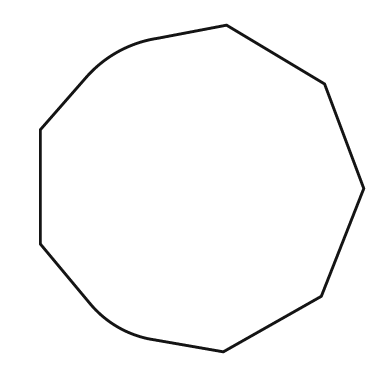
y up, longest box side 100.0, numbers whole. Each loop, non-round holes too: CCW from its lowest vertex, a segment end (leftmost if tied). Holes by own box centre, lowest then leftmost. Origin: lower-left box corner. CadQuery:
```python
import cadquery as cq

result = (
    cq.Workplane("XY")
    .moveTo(56.0, 0.0)
    .lineTo(86.0, 17.0)
    .lineTo(99.0, 50.0)
    .lineTo(87.0, 82.0)
    .lineTo(57.0, 100.0)
    .lineTo(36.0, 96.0)
    .threePointArc((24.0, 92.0), (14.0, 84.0))
    .lineTo(0.0, 68.0)
    .lineTo(0.0, 33.0)
    .lineTo(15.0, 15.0)
    .threePointArc((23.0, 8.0), (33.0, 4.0))
    .close()
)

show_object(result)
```